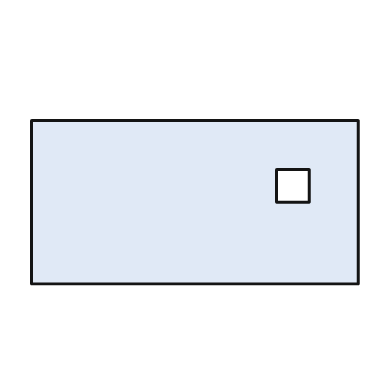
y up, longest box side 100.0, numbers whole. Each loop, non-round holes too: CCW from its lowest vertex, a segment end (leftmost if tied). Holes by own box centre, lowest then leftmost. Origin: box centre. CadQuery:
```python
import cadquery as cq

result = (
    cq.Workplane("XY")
    .moveTo(-50.0, -25.0)
    .lineTo(50.0, -25.0)
    .lineTo(50.0, 25.0)
    .lineTo(-50.0, 25.0)
    .close()
    .moveTo(25.0, 0.0)
    .lineTo(35.0, 0.0)
    .lineTo(35.0, 10.0)
    .lineTo(25.0, 10.0)
    .close()
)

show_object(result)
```